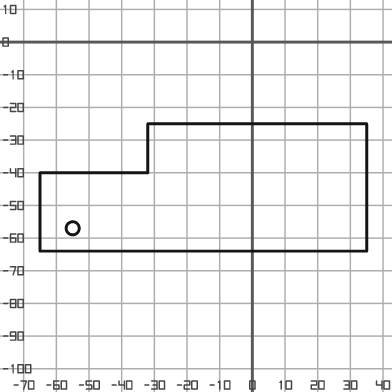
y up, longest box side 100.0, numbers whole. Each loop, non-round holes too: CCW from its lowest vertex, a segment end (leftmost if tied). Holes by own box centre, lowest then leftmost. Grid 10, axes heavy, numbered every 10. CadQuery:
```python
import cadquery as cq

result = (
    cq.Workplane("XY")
    .moveTo(-65.0, -64.0)
    .lineTo(35.0, -64.0)
    .lineTo(35.0, -25.0)
    .lineTo(-32.0, -25.0)
    .lineTo(-32.0, -40.0)
    .lineTo(-65.0, -40.0)
    .close()
    .moveTo(-55.0, -57.0)
    .circle(2.0)
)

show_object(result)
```